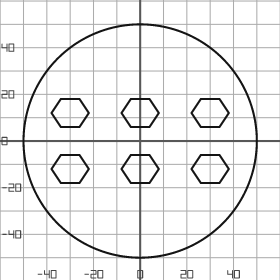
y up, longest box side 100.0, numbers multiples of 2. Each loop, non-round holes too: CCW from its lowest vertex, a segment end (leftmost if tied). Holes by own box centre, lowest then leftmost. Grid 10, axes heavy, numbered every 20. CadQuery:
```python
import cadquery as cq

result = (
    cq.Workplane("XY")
    .moveTo(0.0, 0.0)
    .circle(50.0)
    .moveTo(-34.0, -18.0)
    .lineTo(-26.0, -18.0)
    .lineTo(-22.0, -12.0)
    .lineTo(-26.0, -6.0)
    .lineTo(-34.0, -6.0)
    .lineTo(-38.0, -12.0)
    .close()
    .moveTo(-4.0, -18.0)
    .lineTo(4.0, -18.0)
    .lineTo(8.0, -12.0)
    .lineTo(4.0, -6.0)
    .lineTo(-4.0, -6.0)
    .lineTo(-8.0, -12.0)
    .close()
    .moveTo(26.0, -18.0)
    .lineTo(34.0, -18.0)
    .lineTo(38.0, -12.0)
    .lineTo(34.0, -6.0)
    .lineTo(26.0, -6.0)
    .lineTo(22.0, -12.0)
    .close()
    .moveTo(-34.0, 6.0)
    .lineTo(-26.0, 6.0)
    .lineTo(-22.0, 12.0)
    .lineTo(-26.0, 18.0)
    .lineTo(-34.0, 18.0)
    .lineTo(-38.0, 12.0)
    .close()
    .moveTo(-4.0, 6.0)
    .lineTo(4.0, 6.0)
    .lineTo(8.0, 12.0)
    .lineTo(4.0, 18.0)
    .lineTo(-4.0, 18.0)
    .lineTo(-8.0, 12.0)
    .close()
    .moveTo(26.0, 6.0)
    .lineTo(34.0, 6.0)
    .lineTo(38.0, 12.0)
    .lineTo(34.0, 18.0)
    .lineTo(26.0, 18.0)
    .lineTo(22.0, 12.0)
    .close()
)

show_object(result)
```